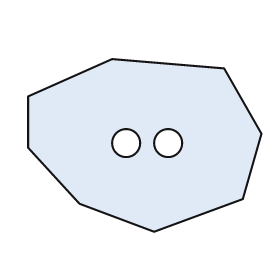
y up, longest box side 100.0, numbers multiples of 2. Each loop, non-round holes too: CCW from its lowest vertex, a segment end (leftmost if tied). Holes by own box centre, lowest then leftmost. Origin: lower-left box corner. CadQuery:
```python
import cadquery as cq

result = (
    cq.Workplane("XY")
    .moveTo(54.0, 0.0)
    .lineTo(92.0, 14.0)
    .lineTo(100.0, 42.0)
    .lineTo(84.0, 70.0)
    .lineTo(36.0, 74.0)
    .lineTo(0.0, 58.0)
    .lineTo(0.0, 36.0)
    .lineTo(22.0, 12.0)
    .close()
    .moveTo(42.0, 38.0)
    .circle(6.0)
    .moveTo(60.0, 38.0)
    .circle(6.0)
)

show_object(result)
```